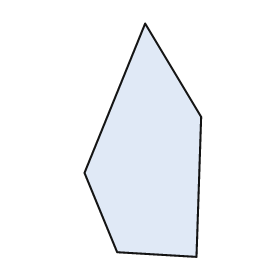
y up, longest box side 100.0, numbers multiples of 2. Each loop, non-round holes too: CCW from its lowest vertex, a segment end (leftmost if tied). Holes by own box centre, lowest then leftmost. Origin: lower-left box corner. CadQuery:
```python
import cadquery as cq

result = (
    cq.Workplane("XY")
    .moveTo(48.0, 0.0)
    .lineTo(50.0, 60.0)
    .lineTo(26.0, 100.0)
    .lineTo(0.0, 36.0)
    .lineTo(14.0, 2.0)
    .close()
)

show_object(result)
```